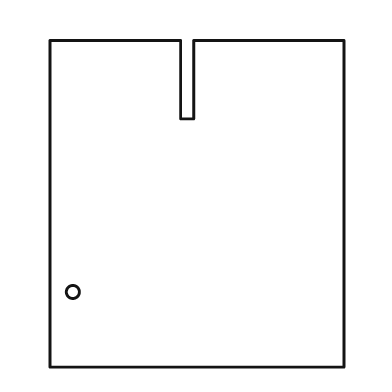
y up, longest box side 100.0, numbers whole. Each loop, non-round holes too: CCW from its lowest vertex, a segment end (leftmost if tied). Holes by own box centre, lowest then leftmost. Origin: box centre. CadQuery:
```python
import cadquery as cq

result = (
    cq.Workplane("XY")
    .moveTo(-45.0, -50.0)
    .lineTo(45.0, -50.0)
    .lineTo(45.0, 50.0)
    .lineTo(-1.0, 50.0)
    .lineTo(-1.0, 26.0)
    .lineTo(-5.0, 26.0)
    .lineTo(-5.0, 50.0)
    .lineTo(-45.0, 50.0)
    .close()
    .moveTo(-38.0, -27.0)
    .circle(2.0)
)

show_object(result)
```